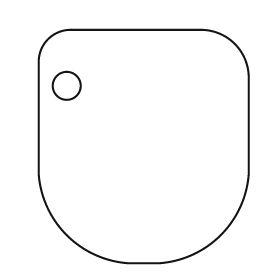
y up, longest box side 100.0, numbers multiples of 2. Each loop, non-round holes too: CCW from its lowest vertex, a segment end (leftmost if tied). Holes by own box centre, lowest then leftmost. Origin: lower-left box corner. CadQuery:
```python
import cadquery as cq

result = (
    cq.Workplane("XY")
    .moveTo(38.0, 0.0)
    .lineTo(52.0, 0.0)
    .threePointArc((78.0, 12.0), (90.0, 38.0))
    .lineTo(90.0, 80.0)
    .threePointArc((84.0, 94.0), (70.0, 100.0))
    .lineTo(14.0, 100.0)
    .threePointArc((4.0, 96.0), (0.0, 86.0))
    .lineTo(0.0, 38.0)
    .threePointArc((12.0, 12.0), (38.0, 0.0))
    .close()
    .moveTo(12.0, 76.0)
    .circle(6.0)
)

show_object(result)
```